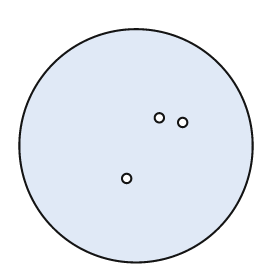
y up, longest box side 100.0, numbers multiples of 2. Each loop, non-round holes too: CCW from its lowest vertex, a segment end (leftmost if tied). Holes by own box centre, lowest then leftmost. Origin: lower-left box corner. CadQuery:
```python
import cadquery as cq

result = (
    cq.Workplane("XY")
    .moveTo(50.0, 50.0)
    .circle(50.0)
    .moveTo(46.0, 36.0)
    .circle(2.0)
    .moveTo(70.0, 60.0)
    .circle(2.0)
    .moveTo(60.0, 62.0)
    .circle(2.0)
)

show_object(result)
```